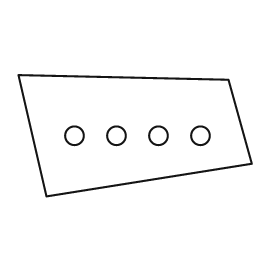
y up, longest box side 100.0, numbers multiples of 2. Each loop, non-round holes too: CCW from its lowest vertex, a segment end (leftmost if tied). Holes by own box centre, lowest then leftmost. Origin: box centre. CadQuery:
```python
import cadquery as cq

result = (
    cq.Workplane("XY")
    .moveTo(-38.0, -26.0)
    .lineTo(50.0, -12.0)
    .lineTo(40.0, 24.0)
    .lineTo(-50.0, 26.0)
    .close()
    .moveTo(-26.0, 0.0)
    .circle(4.0)
    .moveTo(-8.0, 0.0)
    .circle(4.0)
    .moveTo(10.0, 0.0)
    .circle(4.0)
    .moveTo(28.0, 0.0)
    .circle(4.0)
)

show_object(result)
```